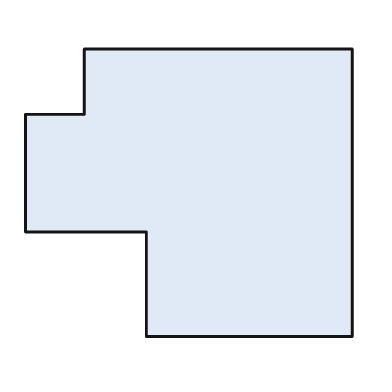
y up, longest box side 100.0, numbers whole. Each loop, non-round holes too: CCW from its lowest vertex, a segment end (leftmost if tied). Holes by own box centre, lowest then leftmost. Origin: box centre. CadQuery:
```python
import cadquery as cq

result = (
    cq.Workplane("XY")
    .moveTo(-13.0, -44.0)
    .lineTo(50.0, -44.0)
    .lineTo(50.0, 44.0)
    .lineTo(-32.0, 44.0)
    .lineTo(-32.0, 24.0)
    .lineTo(-50.0, 24.0)
    .lineTo(-50.0, -12.0)
    .lineTo(-13.0, -12.0)
    .close()
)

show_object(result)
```